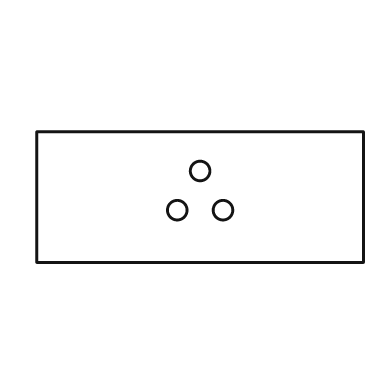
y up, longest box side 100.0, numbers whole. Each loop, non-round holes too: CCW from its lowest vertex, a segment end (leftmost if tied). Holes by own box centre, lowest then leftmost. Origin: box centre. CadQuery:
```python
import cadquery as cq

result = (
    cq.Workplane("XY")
    .moveTo(-50.0, -20.0)
    .lineTo(50.0, -20.0)
    .lineTo(50.0, 20.0)
    .lineTo(-50.0, 20.0)
    .close()
    .moveTo(-7.0, -4.0)
    .circle(3.0)
    .moveTo(7.0, -4.0)
    .circle(3.0)
    .moveTo(0.0, 8.0)
    .circle(3.0)
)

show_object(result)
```